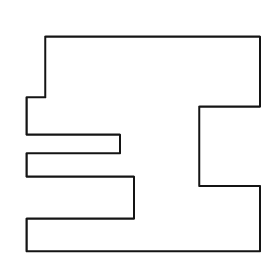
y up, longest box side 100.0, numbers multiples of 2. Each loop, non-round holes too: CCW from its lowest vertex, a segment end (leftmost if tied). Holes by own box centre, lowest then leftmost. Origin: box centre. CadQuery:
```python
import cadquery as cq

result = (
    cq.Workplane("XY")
    .moveTo(-50.0, -46.0)
    .lineTo(50.0, -46.0)
    .lineTo(50.0, -18.0)
    .lineTo(24.0, -18.0)
    .lineTo(24.0, 16.0)
    .lineTo(50.0, 16.0)
    .lineTo(50.0, 46.0)
    .lineTo(-42.0, 46.0)
    .lineTo(-42.0, 20.0)
    .lineTo(-50.0, 20.0)
    .lineTo(-50.0, 4.0)
    .lineTo(-10.0, 4.0)
    .lineTo(-10.0, -4.0)
    .lineTo(-50.0, -4.0)
    .lineTo(-50.0, -14.0)
    .lineTo(-4.0, -14.0)
    .lineTo(-4.0, -32.0)
    .lineTo(-50.0, -32.0)
    .close()
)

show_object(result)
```